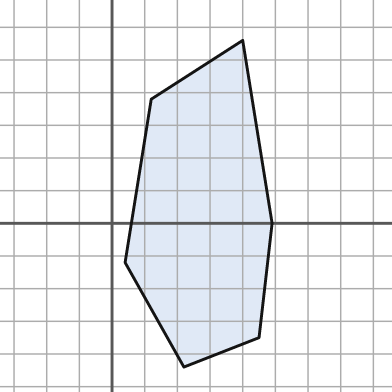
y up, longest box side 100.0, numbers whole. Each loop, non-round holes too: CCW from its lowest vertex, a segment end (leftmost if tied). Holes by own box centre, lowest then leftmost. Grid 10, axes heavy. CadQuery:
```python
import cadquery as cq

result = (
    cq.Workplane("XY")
    .moveTo(22.0, -44.0)
    .lineTo(45.0, -35.0)
    .lineTo(49.0, 0.0)
    .lineTo(40.0, 56.0)
    .lineTo(12.0, 38.0)
    .lineTo(4.0, -12.0)
    .close()
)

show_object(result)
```